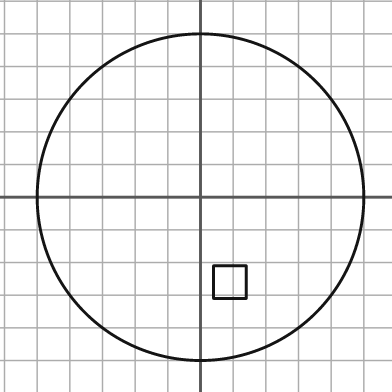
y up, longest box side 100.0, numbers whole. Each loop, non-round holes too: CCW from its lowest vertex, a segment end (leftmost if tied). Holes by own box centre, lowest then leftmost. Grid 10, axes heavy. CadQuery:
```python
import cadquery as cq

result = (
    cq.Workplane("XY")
    .moveTo(0.0, 0.0)
    .circle(50.0)
    .moveTo(4.0, -31.0)
    .lineTo(14.0, -31.0)
    .lineTo(14.0, -21.0)
    .lineTo(4.0, -21.0)
    .close()
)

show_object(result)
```